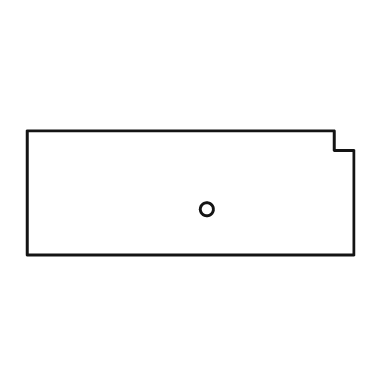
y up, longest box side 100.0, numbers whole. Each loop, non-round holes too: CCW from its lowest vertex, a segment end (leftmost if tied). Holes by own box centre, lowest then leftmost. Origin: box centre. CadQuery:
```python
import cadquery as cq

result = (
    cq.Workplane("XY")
    .moveTo(-50.0, -19.0)
    .lineTo(50.0, -19.0)
    .lineTo(50.0, 13.0)
    .lineTo(44.0, 13.0)
    .lineTo(44.0, 19.0)
    .lineTo(-50.0, 19.0)
    .close()
    .moveTo(5.0, -5.0)
    .circle(2.0)
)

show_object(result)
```